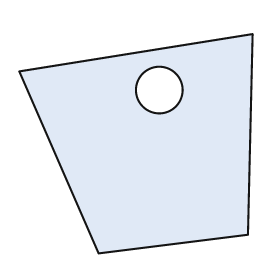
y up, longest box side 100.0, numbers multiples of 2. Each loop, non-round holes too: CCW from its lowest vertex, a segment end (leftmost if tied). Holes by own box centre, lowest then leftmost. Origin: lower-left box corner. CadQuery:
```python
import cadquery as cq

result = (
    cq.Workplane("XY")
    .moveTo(34.0, 0.0)
    .lineTo(98.0, 8.0)
    .lineTo(100.0, 94.0)
    .lineTo(0.0, 78.0)
    .close()
    .moveTo(60.0, 70.0)
    .circle(10.0)
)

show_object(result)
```